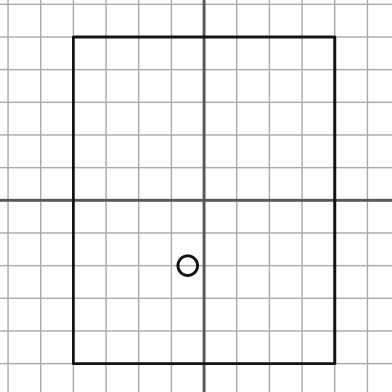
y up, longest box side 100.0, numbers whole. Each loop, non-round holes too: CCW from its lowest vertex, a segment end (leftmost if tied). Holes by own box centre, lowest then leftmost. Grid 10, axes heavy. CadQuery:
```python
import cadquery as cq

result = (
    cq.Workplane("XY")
    .moveTo(-40.0, -50.0)
    .lineTo(40.0, -50.0)
    .lineTo(40.0, 50.0)
    .lineTo(-40.0, 50.0)
    .close()
    .moveTo(-5.0, -20.0)
    .circle(3.0)
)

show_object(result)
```